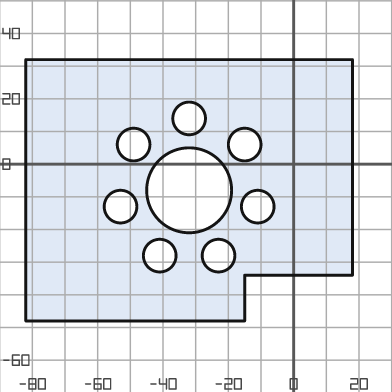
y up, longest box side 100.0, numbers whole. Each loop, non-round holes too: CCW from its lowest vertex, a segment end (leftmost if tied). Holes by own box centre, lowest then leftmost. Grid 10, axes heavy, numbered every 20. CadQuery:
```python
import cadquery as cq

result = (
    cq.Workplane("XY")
    .moveTo(-82.0, -48.0)
    .lineTo(-15.0, -48.0)
    .lineTo(-15.0, -34.0)
    .lineTo(18.0, -34.0)
    .lineTo(18.0, 32.0)
    .lineTo(-82.0, 32.0)
    .close()
    .moveTo(-41.0, -28.0)
    .circle(5.0)
    .moveTo(-23.0, -28.0)
    .circle(5.0)
    .moveTo(-53.0, -13.0)
    .circle(5.0)
    .moveTo(-11.0, -13.0)
    .circle(5.0)
    .moveTo(-32.0, -8.0)
    .circle(13.0)
    .moveTo(-49.0, 6.0)
    .circle(5.0)
    .moveTo(-15.0, 6.0)
    .circle(5.0)
    .moveTo(-32.0, 14.0)
    .circle(5.0)
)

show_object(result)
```